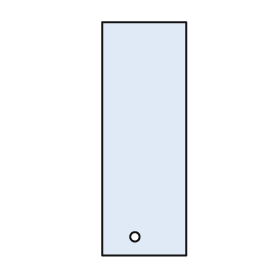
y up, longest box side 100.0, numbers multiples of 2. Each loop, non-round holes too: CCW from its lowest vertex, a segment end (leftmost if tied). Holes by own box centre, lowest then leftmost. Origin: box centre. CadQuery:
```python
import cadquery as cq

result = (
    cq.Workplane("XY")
    .moveTo(-18.0, -50.0)
    .lineTo(18.0, -50.0)
    .lineTo(18.0, 50.0)
    .lineTo(-18.0, 50.0)
    .close()
    .moveTo(-4.0, -42.0)
    .circle(2.0)
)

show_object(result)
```